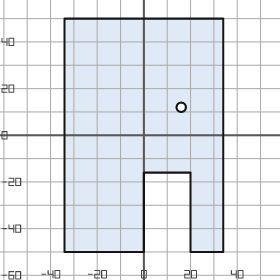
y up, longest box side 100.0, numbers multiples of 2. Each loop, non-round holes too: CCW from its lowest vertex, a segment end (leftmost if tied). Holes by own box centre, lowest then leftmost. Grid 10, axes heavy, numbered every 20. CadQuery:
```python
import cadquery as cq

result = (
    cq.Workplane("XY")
    .moveTo(-34.0, -50.0)
    .lineTo(0.0, -50.0)
    .lineTo(0.0, -16.0)
    .lineTo(20.0, -16.0)
    .lineTo(20.0, -50.0)
    .lineTo(34.0, -50.0)
    .lineTo(34.0, 50.0)
    .lineTo(-34.0, 50.0)
    .close()
    .moveTo(16.0, 12.0)
    .circle(2.0)
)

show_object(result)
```